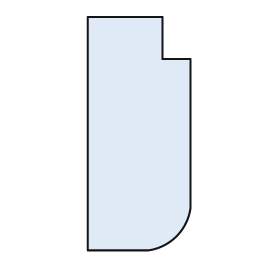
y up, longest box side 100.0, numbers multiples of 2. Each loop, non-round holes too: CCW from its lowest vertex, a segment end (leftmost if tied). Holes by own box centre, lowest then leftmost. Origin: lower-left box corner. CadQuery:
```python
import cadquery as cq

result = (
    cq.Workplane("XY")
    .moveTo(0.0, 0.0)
    .lineTo(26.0, 0.0)
    .threePointArc((38.0, 6.0), (44.0, 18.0))
    .lineTo(44.0, 82.0)
    .lineTo(32.0, 82.0)
    .lineTo(32.0, 100.0)
    .lineTo(0.0, 100.0)
    .close()
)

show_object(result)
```